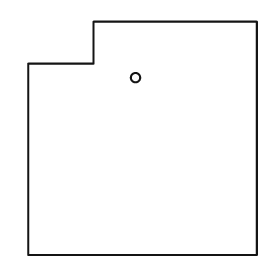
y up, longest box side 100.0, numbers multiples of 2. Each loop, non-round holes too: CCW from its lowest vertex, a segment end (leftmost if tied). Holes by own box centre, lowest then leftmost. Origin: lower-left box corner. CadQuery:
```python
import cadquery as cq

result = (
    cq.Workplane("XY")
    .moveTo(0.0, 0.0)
    .lineTo(98.0, 0.0)
    .lineTo(98.0, 100.0)
    .lineTo(28.0, 100.0)
    .lineTo(28.0, 82.0)
    .lineTo(0.0, 82.0)
    .close()
    .moveTo(46.0, 76.0)
    .circle(2.0)
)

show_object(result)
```